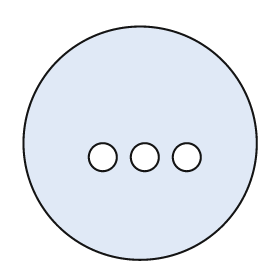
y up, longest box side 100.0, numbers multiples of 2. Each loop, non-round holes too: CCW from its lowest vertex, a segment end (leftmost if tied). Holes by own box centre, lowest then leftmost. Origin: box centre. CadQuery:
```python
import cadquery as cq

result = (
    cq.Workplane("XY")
    .moveTo(0.0, 0.0)
    .circle(50.0)
    .moveTo(-16.0, -6.0)
    .circle(6.0)
    .moveTo(2.0, -6.0)
    .circle(6.0)
    .moveTo(20.0, -6.0)
    .circle(6.0)
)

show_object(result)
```